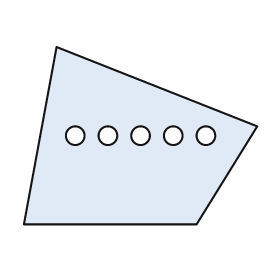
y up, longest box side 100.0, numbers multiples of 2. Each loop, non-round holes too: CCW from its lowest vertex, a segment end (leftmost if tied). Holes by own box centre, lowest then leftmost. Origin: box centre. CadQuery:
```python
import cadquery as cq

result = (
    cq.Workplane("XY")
    .moveTo(-50.0, -38.0)
    .lineTo(24.0, -38.0)
    .lineTo(50.0, 4.0)
    .lineTo(-36.0, 38.0)
    .close()
    .moveTo(-28.0, 0.0)
    .circle(4.0)
    .moveTo(-14.0, 0.0)
    .circle(4.0)
    .moveTo(0.0, 0.0)
    .circle(4.0)
    .moveTo(14.0, 0.0)
    .circle(4.0)
    .moveTo(28.0, 0.0)
    .circle(4.0)
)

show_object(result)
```